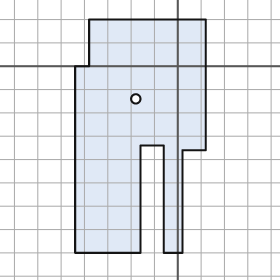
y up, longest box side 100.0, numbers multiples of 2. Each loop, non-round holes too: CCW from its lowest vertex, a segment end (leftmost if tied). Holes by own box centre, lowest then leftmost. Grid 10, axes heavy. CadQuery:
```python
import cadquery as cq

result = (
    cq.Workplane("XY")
    .moveTo(-44.0, -80.0)
    .lineTo(-16.0, -80.0)
    .lineTo(-16.0, -34.0)
    .lineTo(-6.0, -34.0)
    .lineTo(-6.0, -80.0)
    .lineTo(2.0, -80.0)
    .lineTo(2.0, -36.0)
    .lineTo(12.0, -36.0)
    .lineTo(12.0, 20.0)
    .lineTo(-38.0, 20.0)
    .lineTo(-38.0, 0.0)
    .lineTo(-44.0, 0.0)
    .close()
    .moveTo(-18.0, -14.0)
    .circle(2.0)
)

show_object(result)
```